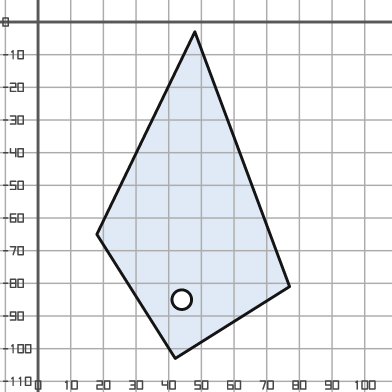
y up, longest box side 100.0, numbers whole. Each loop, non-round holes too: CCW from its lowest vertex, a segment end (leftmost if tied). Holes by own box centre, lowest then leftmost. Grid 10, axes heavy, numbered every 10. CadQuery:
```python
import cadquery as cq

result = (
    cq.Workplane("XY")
    .moveTo(42.0, -103.0)
    .lineTo(77.0, -81.0)
    .lineTo(48.0, -3.0)
    .lineTo(18.0, -65.0)
    .close()
    .moveTo(44.0, -85.0)
    .circle(3.0)
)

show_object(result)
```